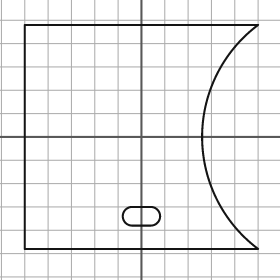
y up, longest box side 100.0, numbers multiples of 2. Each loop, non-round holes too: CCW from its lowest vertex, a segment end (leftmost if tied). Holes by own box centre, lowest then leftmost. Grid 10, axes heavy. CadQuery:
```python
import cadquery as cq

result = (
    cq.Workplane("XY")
    .moveTo(-50.0, -48.0)
    .lineTo(50.0, -48.0)
    .threePointArc((26.0, 0.0), (50.0, 48.0))
    .lineTo(-50.0, 48.0)
    .close()
    .moveTo(-4.0, -38.0)
    .lineTo(4.0, -38.0)
    .threePointArc((8.0, -34.0), (4.0, -30.0))
    .lineTo(-4.0, -30.0)
    .threePointArc((-8.0, -34.0), (-4.0, -38.0))
    .close()
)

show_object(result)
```